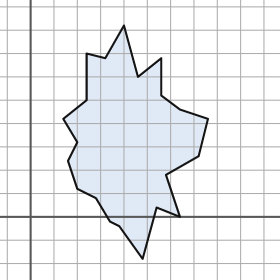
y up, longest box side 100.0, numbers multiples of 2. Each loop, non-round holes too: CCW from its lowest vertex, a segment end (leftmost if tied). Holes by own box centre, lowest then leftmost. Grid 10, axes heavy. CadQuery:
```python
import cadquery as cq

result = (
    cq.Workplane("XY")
    .moveTo(48.0, -18.0)
    .lineTo(54.0, 4.0)
    .lineTo(64.0, 0.0)
    .lineTo(58.0, 18.0)
    .lineTo(72.0, 26.0)
    .lineTo(76.0, 42.0)
    .lineTo(64.0, 46.0)
    .lineTo(56.0, 52.0)
    .lineTo(56.0, 68.0)
    .lineTo(46.0, 60.0)
    .lineTo(40.0, 82.0)
    .lineTo(32.0, 68.0)
    .lineTo(24.0, 70.0)
    .lineTo(24.0, 50.0)
    .lineTo(14.0, 42.0)
    .lineTo(20.0, 32.0)
    .lineTo(16.0, 24.0)
    .lineTo(20.0, 12.0)
    .lineTo(28.0, 8.0)
    .lineTo(34.0, -2.0)
    .lineTo(38.0, -4.0)
    .close()
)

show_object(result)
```